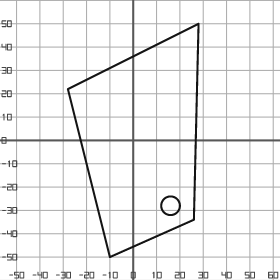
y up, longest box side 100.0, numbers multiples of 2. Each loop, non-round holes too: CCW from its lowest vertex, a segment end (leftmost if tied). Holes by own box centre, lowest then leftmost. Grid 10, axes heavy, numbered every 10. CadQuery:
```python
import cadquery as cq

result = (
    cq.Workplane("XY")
    .moveTo(-10.0, -50.0)
    .lineTo(26.0, -34.0)
    .lineTo(28.0, 50.0)
    .lineTo(-28.0, 22.0)
    .close()
    .moveTo(16.0, -28.0)
    .circle(4.0)
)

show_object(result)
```